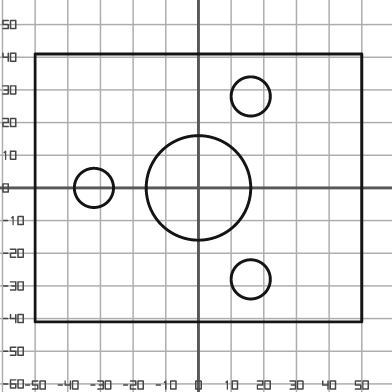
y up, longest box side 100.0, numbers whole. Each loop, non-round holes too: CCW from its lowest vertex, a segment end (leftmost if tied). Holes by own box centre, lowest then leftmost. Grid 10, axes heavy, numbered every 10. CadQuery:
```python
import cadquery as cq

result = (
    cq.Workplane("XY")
    .moveTo(-50.0, -41.0)
    .lineTo(50.0, -41.0)
    .lineTo(50.0, 41.0)
    .lineTo(-50.0, 41.0)
    .close()
    .moveTo(16.0, -28.0)
    .circle(6.0)
    .moveTo(-32.0, 0.0)
    .circle(6.0)
    .moveTo(0.0, 0.0)
    .circle(16.0)
    .moveTo(16.0, 28.0)
    .circle(6.0)
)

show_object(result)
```